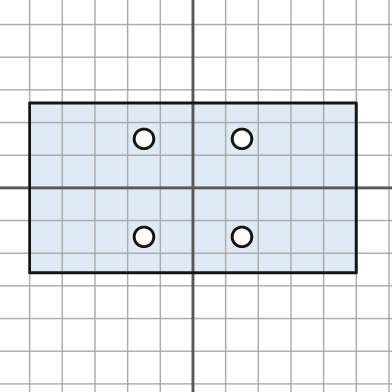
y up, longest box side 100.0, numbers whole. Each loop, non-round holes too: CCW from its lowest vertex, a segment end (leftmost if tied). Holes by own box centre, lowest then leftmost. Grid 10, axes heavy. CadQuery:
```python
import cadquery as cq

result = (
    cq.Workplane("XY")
    .moveTo(-50.0, -26.0)
    .lineTo(50.0, -26.0)
    .lineTo(50.0, 26.0)
    .lineTo(-50.0, 26.0)
    .close()
    .moveTo(-15.0, -15.0)
    .circle(3.0)
    .moveTo(15.0, -15.0)
    .circle(3.0)
    .moveTo(-15.0, 15.0)
    .circle(3.0)
    .moveTo(15.0, 15.0)
    .circle(3.0)
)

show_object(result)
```